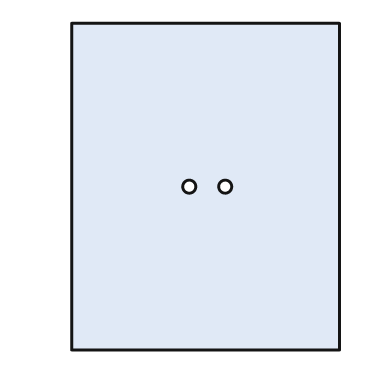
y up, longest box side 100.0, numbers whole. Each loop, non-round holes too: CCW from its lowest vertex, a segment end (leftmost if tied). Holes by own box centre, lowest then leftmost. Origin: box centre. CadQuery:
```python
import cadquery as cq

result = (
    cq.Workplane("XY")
    .moveTo(-41.0, -50.0)
    .lineTo(41.0, -50.0)
    .lineTo(41.0, 50.0)
    .lineTo(-41.0, 50.0)
    .close()
    .moveTo(-5.0, 0.0)
    .circle(2.0)
    .moveTo(6.0, 0.0)
    .circle(2.0)
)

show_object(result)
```